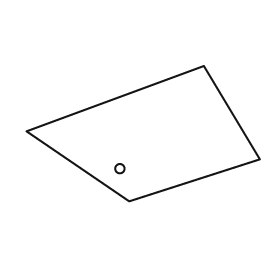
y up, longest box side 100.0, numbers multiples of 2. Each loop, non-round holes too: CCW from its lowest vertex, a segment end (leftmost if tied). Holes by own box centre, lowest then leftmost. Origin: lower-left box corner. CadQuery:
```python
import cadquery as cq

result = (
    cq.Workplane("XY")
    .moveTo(44.0, 0.0)
    .lineTo(100.0, 18.0)
    .lineTo(76.0, 58.0)
    .lineTo(0.0, 30.0)
    .close()
    .moveTo(40.0, 14.0)
    .circle(2.0)
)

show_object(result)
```